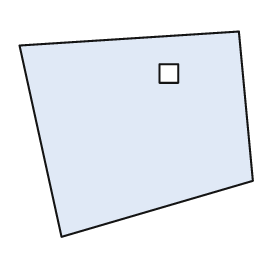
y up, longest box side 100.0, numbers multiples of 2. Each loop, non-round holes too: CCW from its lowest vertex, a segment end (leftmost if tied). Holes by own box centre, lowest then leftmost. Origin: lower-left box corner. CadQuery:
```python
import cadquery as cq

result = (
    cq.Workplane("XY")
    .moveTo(18.0, 0.0)
    .lineTo(100.0, 24.0)
    .lineTo(94.0, 88.0)
    .lineTo(0.0, 82.0)
    .close()
    .moveTo(60.0, 66.0)
    .lineTo(68.0, 66.0)
    .lineTo(68.0, 74.0)
    .lineTo(60.0, 74.0)
    .close()
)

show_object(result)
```